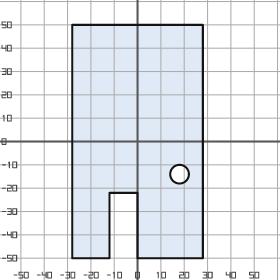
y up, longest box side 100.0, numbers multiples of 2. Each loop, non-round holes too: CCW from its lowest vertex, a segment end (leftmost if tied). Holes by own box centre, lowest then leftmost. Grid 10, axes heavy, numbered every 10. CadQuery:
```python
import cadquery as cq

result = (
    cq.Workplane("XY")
    .moveTo(-28.0, -50.0)
    .lineTo(-12.0, -50.0)
    .lineTo(-12.0, -22.0)
    .lineTo(0.0, -22.0)
    .lineTo(0.0, -50.0)
    .lineTo(28.0, -50.0)
    .lineTo(28.0, 50.0)
    .lineTo(-28.0, 50.0)
    .close()
    .moveTo(18.0, -14.0)
    .circle(4.0)
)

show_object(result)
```